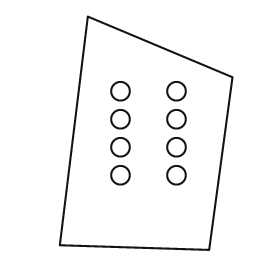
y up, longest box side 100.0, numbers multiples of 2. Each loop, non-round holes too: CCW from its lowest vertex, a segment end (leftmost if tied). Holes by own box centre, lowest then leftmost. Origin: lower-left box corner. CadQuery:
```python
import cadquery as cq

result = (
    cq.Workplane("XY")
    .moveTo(64.0, 0.0)
    .lineTo(74.0, 74.0)
    .lineTo(12.0, 100.0)
    .lineTo(0.0, 2.0)
    .close()
    .moveTo(26.0, 32.0)
    .circle(4.0)
    .moveTo(50.0, 32.0)
    .circle(4.0)
    .moveTo(26.0, 44.0)
    .circle(4.0)
    .moveTo(50.0, 44.0)
    .circle(4.0)
    .moveTo(26.0, 56.0)
    .circle(4.0)
    .moveTo(50.0, 56.0)
    .circle(4.0)
    .moveTo(26.0, 68.0)
    .circle(4.0)
    .moveTo(50.0, 68.0)
    .circle(4.0)
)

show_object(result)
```